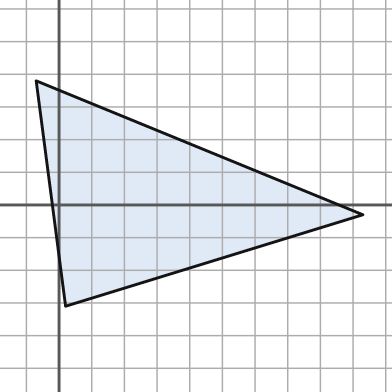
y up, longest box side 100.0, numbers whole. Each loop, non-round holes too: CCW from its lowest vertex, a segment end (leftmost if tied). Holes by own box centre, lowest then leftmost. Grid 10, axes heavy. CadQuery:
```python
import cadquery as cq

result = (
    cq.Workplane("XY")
    .moveTo(2.0, -31.0)
    .lineTo(93.0, -3.0)
    .lineTo(-7.0, 38.0)
    .close()
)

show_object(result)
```